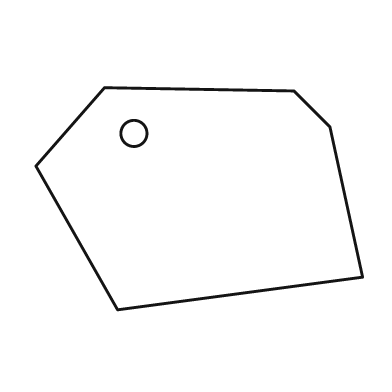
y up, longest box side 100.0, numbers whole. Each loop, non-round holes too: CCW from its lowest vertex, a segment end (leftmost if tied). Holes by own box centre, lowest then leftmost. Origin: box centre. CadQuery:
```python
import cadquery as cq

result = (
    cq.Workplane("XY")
    .moveTo(-25.0, -34.0)
    .lineTo(50.0, -24.0)
    .lineTo(40.0, 22.0)
    .lineTo(29.0, 33.0)
    .lineTo(-29.0, 34.0)
    .lineTo(-50.0, 10.0)
    .close()
    .moveTo(-20.0, 20.0)
    .circle(4.0)
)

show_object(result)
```